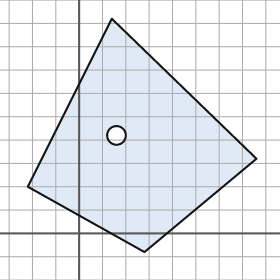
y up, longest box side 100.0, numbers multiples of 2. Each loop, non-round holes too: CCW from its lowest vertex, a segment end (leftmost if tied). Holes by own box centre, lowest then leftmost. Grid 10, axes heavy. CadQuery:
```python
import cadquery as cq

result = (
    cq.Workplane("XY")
    .moveTo(28.0, -8.0)
    .lineTo(76.0, 32.0)
    .lineTo(14.0, 92.0)
    .lineTo(-22.0, 20.0)
    .close()
    .moveTo(16.0, 42.0)
    .circle(4.0)
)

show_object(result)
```